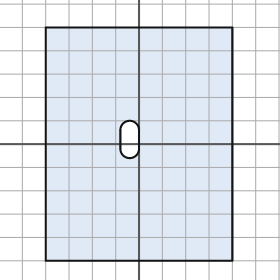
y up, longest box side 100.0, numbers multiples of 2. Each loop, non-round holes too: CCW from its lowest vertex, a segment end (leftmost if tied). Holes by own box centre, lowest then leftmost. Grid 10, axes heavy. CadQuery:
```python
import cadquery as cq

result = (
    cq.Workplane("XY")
    .moveTo(-40.0, -50.0)
    .lineTo(40.0, -50.0)
    .lineTo(40.0, 50.0)
    .lineTo(-40.0, 50.0)
    .close()
    .moveTo(-8.0, -2.0)
    .threePointArc((-4.0, -6.0), (0.0, -2.0))
    .lineTo(0.0, 6.0)
    .threePointArc((-4.0, 10.0), (-8.0, 6.0))
    .close()
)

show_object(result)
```